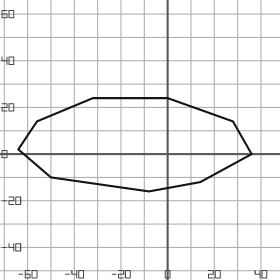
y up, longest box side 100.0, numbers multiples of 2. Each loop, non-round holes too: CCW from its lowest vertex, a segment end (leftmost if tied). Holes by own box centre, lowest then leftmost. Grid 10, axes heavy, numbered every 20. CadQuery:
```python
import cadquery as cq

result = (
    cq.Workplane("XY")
    .moveTo(-8.0, -16.0)
    .lineTo(14.0, -12.0)
    .lineTo(36.0, 0.0)
    .lineTo(28.0, 14.0)
    .lineTo(0.0, 24.0)
    .lineTo(-32.0, 24.0)
    .lineTo(-56.0, 14.0)
    .lineTo(-64.0, 2.0)
    .lineTo(-50.0, -10.0)
    .close()
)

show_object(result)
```